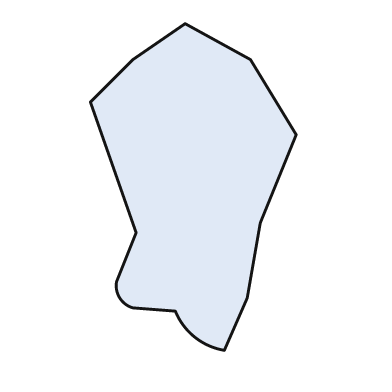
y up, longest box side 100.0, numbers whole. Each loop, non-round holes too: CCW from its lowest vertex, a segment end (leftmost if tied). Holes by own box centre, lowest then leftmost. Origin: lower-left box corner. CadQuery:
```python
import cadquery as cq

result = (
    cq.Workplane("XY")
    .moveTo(41.0, 0.0)
    .lineTo(48.0, 16.0)
    .lineTo(52.0, 39.0)
    .lineTo(63.0, 66.0)
    .lineTo(49.0, 89.0)
    .lineTo(29.0, 100.0)
    .lineTo(13.0, 89.0)
    .lineTo(0.0, 76.0)
    .lineTo(14.0, 36.0)
    .lineTo(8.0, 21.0)
    .threePointArc((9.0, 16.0), (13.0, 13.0))
    .lineTo(26.0, 12.0)
    .threePointArc((32.0, 4.0), (41.0, 0.0))
    .close()
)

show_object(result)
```